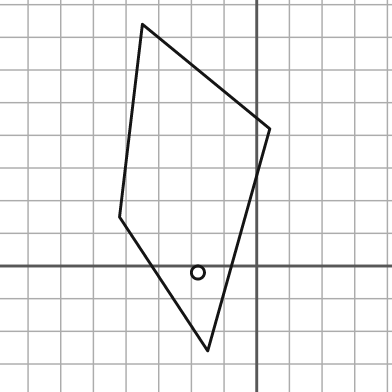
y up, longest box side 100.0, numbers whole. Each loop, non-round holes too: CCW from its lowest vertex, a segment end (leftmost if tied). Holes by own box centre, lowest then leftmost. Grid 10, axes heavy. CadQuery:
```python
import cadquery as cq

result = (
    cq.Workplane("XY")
    .moveTo(-15.0, -26.0)
    .lineTo(4.0, 42.0)
    .lineTo(-35.0, 74.0)
    .lineTo(-42.0, 15.0)
    .close()
    .moveTo(-18.0, -2.0)
    .circle(2.0)
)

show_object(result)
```